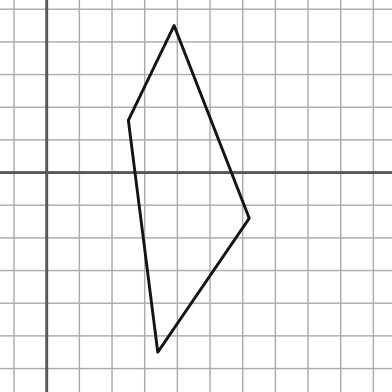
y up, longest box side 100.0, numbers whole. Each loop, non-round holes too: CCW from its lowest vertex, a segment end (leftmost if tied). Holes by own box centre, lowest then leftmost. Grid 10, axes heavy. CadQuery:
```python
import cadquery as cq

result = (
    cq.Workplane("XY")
    .moveTo(34.0, -55.0)
    .lineTo(62.0, -14.0)
    .lineTo(39.0, 45.0)
    .lineTo(25.0, 16.0)
    .close()
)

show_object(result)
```